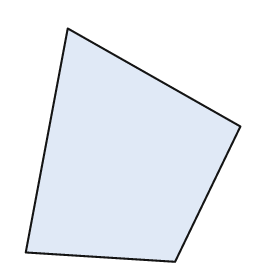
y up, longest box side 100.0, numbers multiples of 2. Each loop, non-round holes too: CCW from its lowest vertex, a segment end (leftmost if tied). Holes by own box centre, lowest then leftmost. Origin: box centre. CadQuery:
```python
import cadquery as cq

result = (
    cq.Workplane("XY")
    .moveTo(18.0, -50.0)
    .lineTo(46.0, 8.0)
    .lineTo(-28.0, 50.0)
    .lineTo(-46.0, -46.0)
    .close()
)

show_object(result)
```